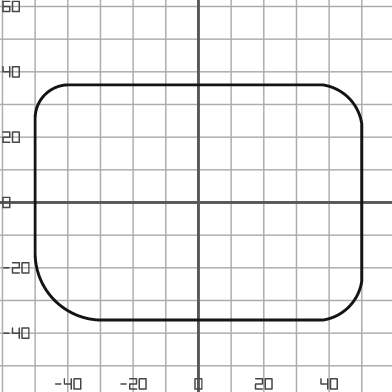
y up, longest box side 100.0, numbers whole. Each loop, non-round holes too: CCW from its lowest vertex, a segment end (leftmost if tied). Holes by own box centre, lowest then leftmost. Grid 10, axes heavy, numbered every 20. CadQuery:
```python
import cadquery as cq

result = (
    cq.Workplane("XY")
    .moveTo(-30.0, -36.0)
    .lineTo(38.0, -36.0)
    .threePointArc((46.0, -32.0), (50.0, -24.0))
    .lineTo(50.0, 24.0)
    .threePointArc((46.0, 32.0), (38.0, 36.0))
    .lineTo(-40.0, 36.0)
    .threePointArc((-47.0, 33.0), (-50.0, 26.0))
    .lineTo(-50.0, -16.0)
    .threePointArc((-44.0, -30.0), (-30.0, -36.0))
    .close()
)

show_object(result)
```